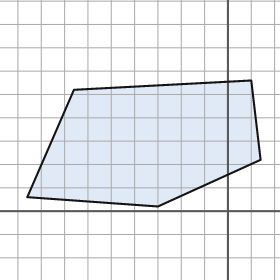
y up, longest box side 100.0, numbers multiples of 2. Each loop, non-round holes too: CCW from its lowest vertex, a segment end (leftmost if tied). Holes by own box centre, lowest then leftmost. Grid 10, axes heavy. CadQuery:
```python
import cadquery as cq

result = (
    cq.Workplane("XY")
    .moveTo(-30.0, 2.0)
    .lineTo(14.0, 22.0)
    .lineTo(10.0, 56.0)
    .lineTo(-66.0, 52.0)
    .lineTo(-86.0, 6.0)
    .close()
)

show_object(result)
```